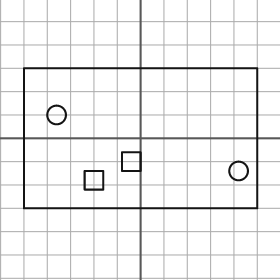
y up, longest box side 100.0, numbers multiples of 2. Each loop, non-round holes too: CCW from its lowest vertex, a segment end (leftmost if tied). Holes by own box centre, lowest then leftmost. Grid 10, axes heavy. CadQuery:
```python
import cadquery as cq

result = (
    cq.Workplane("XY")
    .moveTo(-50.0, -30.0)
    .lineTo(50.0, -30.0)
    .lineTo(50.0, 30.0)
    .lineTo(-50.0, 30.0)
    .close()
    .moveTo(-24.0, -22.0)
    .lineTo(-16.0, -22.0)
    .lineTo(-16.0, -14.0)
    .lineTo(-24.0, -14.0)
    .close()
    .moveTo(42.0, -14.0)
    .circle(4.0)
    .moveTo(-8.0, -14.0)
    .lineTo(0.0, -14.0)
    .lineTo(0.0, -6.0)
    .lineTo(-8.0, -6.0)
    .close()
    .moveTo(-36.0, 10.0)
    .circle(4.0)
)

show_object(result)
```